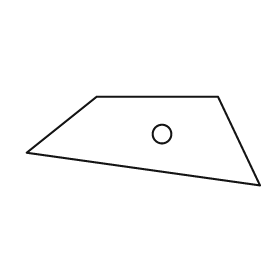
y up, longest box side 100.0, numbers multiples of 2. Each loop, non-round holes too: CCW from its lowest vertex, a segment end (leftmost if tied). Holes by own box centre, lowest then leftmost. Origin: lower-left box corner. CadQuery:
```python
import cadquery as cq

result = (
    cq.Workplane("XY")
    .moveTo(100.0, 0.0)
    .lineTo(82.0, 38.0)
    .lineTo(30.0, 38.0)
    .lineTo(0.0, 14.0)
    .close()
    .moveTo(58.0, 22.0)
    .circle(4.0)
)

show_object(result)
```